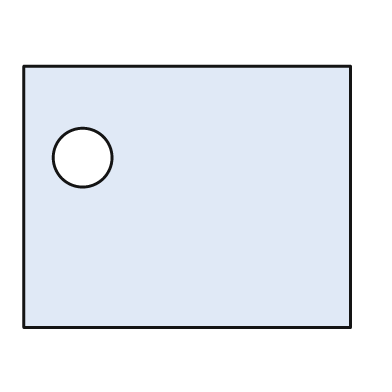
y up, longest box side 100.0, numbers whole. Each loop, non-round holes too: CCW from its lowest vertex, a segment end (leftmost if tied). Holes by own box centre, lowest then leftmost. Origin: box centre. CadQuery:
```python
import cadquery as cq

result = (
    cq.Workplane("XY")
    .moveTo(-50.0, -40.0)
    .lineTo(50.0, -40.0)
    .lineTo(50.0, 40.0)
    .lineTo(-50.0, 40.0)
    .close()
    .moveTo(-32.0, 12.0)
    .circle(9.0)
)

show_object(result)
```